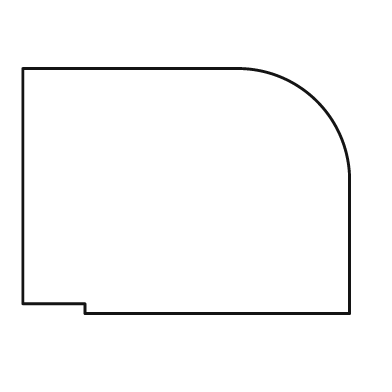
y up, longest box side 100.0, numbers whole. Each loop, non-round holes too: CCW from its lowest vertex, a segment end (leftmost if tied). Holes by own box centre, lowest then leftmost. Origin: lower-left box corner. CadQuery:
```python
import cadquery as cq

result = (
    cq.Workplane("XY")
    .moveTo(19.0, 0.0)
    .lineTo(100.0, 0.0)
    .lineTo(100.0, 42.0)
    .threePointArc((90.0, 65.0), (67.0, 75.0))
    .lineTo(0.0, 75.0)
    .lineTo(0.0, 3.0)
    .lineTo(19.0, 3.0)
    .close()
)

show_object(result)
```